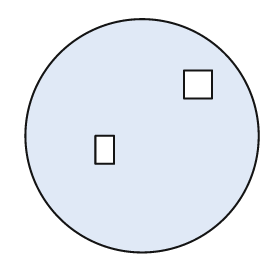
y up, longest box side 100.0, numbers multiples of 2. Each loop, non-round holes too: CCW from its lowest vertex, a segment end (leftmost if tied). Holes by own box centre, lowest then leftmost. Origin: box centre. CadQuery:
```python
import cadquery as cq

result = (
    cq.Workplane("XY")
    .moveTo(0.0, 0.0)
    .circle(50.0)
    .moveTo(-20.0, -12.0)
    .lineTo(-12.0, -12.0)
    .lineTo(-12.0, 0.0)
    .lineTo(-20.0, 0.0)
    .close()
    .moveTo(18.0, 16.0)
    .lineTo(30.0, 16.0)
    .lineTo(30.0, 28.0)
    .lineTo(18.0, 28.0)
    .close()
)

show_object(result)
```